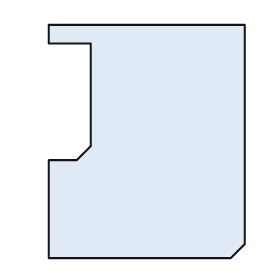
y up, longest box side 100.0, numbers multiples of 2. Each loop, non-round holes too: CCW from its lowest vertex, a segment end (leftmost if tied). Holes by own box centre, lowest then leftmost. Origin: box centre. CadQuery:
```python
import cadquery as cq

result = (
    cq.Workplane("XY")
    .moveTo(-42.0, -50.0)
    .lineTo(36.0, -50.0)
    .lineTo(42.0, -44.0)
    .lineTo(42.0, 50.0)
    .lineTo(-42.0, 50.0)
    .lineTo(-42.0, 42.0)
    .lineTo(-24.0, 42.0)
    .lineTo(-24.0, -2.0)
    .lineTo(-30.0, -8.0)
    .lineTo(-42.0, -8.0)
    .close()
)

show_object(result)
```